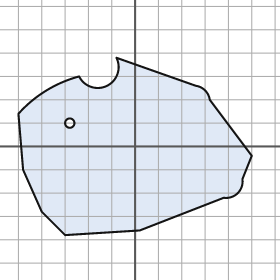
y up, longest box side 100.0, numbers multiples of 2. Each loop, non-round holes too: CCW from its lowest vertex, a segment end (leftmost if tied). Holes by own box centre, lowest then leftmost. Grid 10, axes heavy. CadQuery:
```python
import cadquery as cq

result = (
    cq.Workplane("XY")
    .moveTo(-30.0, -38.0)
    .lineTo(2.0, -36.0)
    .lineTo(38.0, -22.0)
    .threePointArc((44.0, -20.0), (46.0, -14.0))
    .lineTo(50.0, -4.0)
    .lineTo(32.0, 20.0)
    .threePointArc((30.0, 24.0), (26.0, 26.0))
    .lineTo(-8.0, 38.0)
    .threePointArc((-12.0, 26.0), (-24.0, 30.0))
    .threePointArc((-38.0, 24.0), (-50.0, 14.0))
    .lineTo(-48.0, -10.0)
    .lineTo(-40.0, -28.0)
    .close()
    .moveTo(-28.0, 10.0)
    .circle(2.0)
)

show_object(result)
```